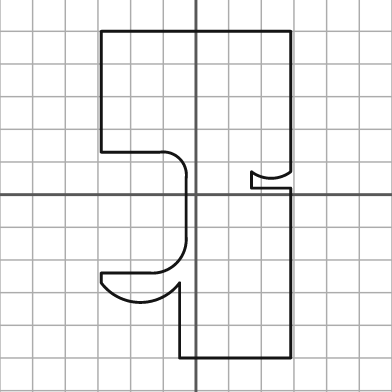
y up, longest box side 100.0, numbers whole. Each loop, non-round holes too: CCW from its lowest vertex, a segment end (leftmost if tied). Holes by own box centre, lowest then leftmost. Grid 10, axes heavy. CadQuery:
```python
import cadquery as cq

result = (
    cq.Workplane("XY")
    .moveTo(-5.0, -50.0)
    .lineTo(29.0, -50.0)
    .lineTo(29.0, 2.0)
    .lineTo(17.0, 2.0)
    .lineTo(17.0, 7.0)
    .threePointArc((23.0, 5.0), (29.0, 7.0))
    .lineTo(29.0, 50.0)
    .lineTo(-29.0, 50.0)
    .lineTo(-29.0, 13.0)
    .lineTo(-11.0, 13.0)
    .threePointArc((-5.0, 11.0), (-3.0, 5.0))
    .lineTo(-3.0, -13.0)
    .threePointArc((-6.0, -21.0), (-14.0, -24.0))
    .lineTo(-29.0, -24.0)
    .lineTo(-29.0, -27.0)
    .threePointArc((-17.0, -33.0), (-5.0, -27.0))
    .close()
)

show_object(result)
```